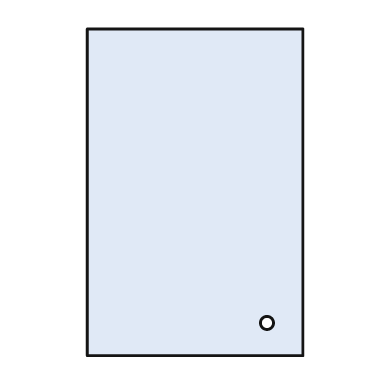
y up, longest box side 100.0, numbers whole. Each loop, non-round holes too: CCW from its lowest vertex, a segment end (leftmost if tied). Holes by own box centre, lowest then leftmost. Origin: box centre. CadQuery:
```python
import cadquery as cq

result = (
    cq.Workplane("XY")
    .moveTo(-33.0, -50.0)
    .lineTo(33.0, -50.0)
    .lineTo(33.0, 50.0)
    .lineTo(-33.0, 50.0)
    .close()
    .moveTo(22.0, -40.0)
    .circle(2.0)
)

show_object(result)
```